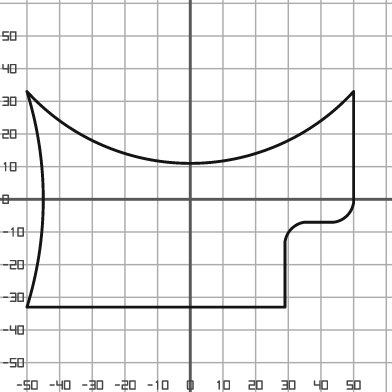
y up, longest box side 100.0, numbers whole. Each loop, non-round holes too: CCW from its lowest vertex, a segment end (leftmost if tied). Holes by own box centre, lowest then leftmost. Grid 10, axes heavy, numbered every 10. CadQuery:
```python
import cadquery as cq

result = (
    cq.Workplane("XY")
    .moveTo(-50.0, -33.0)
    .lineTo(29.0, -33.0)
    .lineTo(29.0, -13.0)
    .threePointArc((31.0, -9.0), (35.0, -7.0))
    .lineTo(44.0, -7.0)
    .threePointArc((48.0, -5.0), (50.0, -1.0))
    .lineTo(50.0, 33.0)
    .threePointArc((0.0, 11.0), (-50.0, 33.0))
    .threePointArc((-45.0, 0.0), (-50.0, -33.0))
    .close()
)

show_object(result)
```